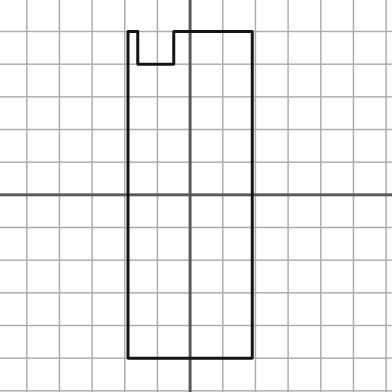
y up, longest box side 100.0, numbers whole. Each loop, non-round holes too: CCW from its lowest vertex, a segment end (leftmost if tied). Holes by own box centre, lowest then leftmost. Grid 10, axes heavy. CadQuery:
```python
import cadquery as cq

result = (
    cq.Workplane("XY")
    .moveTo(-19.0, -50.0)
    .lineTo(19.0, -50.0)
    .lineTo(19.0, 50.0)
    .lineTo(-5.0, 50.0)
    .lineTo(-5.0, 40.0)
    .lineTo(-16.0, 40.0)
    .lineTo(-16.0, 50.0)
    .lineTo(-19.0, 50.0)
    .close()
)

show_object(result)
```